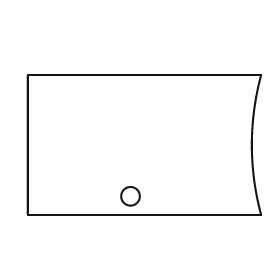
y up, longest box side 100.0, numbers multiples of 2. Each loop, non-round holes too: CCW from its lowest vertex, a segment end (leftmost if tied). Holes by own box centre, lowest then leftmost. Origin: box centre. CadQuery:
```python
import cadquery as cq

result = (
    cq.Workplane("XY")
    .moveTo(-50.0, -30.0)
    .lineTo(50.0, -30.0)
    .threePointArc((46.0, 0.0), (50.0, 30.0))
    .lineTo(-50.0, 30.0)
    .close()
    .moveTo(-6.0, -22.0)
    .circle(4.0)
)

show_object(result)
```